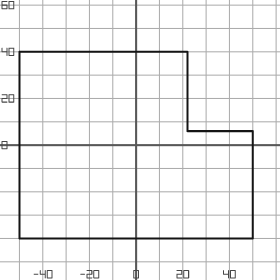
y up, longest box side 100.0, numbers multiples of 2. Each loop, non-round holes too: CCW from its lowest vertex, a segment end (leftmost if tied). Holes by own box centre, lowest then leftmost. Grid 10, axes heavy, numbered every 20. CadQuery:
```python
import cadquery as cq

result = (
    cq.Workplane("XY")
    .moveTo(-50.0, -40.0)
    .lineTo(50.0, -40.0)
    .lineTo(50.0, 6.0)
    .lineTo(22.0, 6.0)
    .lineTo(22.0, 40.0)
    .lineTo(-50.0, 40.0)
    .close()
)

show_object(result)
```